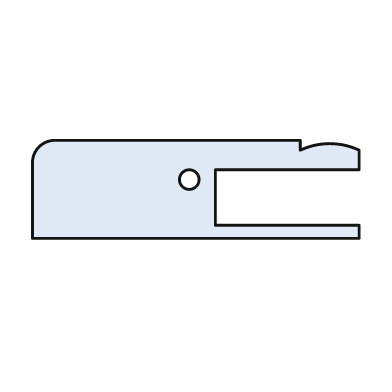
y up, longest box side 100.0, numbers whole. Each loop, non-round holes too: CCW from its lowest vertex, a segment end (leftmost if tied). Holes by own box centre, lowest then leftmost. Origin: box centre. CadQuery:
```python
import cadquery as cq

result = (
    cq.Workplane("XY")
    .moveTo(-50.0, -15.0)
    .lineTo(50.0, -15.0)
    .lineTo(50.0, -11.0)
    .lineTo(6.0, -11.0)
    .lineTo(6.0, 6.0)
    .lineTo(50.0, 6.0)
    .lineTo(50.0, 12.0)
    .threePointArc((41.0, 14.0), (32.0, 12.0))
    .lineTo(32.0, 15.0)
    .lineTo(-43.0, 15.0)
    .threePointArc((-48.0, 13.0), (-50.0, 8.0))
    .close()
    .moveTo(-2.0, 3.0)
    .circle(3.0)
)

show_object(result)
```